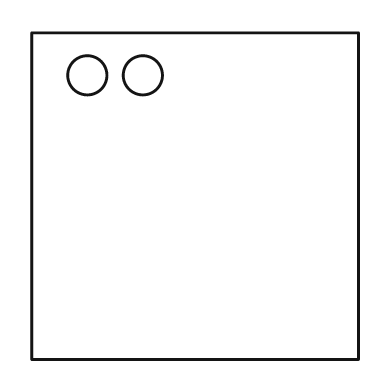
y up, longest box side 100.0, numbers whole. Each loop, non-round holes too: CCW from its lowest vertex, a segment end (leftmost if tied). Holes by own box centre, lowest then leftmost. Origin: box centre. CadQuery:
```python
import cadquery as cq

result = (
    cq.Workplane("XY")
    .moveTo(-50.0, -50.0)
    .lineTo(50.0, -50.0)
    .lineTo(50.0, 50.0)
    .lineTo(-50.0, 50.0)
    .close()
    .moveTo(-33.0, 37.0)
    .circle(6.0)
    .moveTo(-16.0, 37.0)
    .circle(6.0)
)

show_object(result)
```